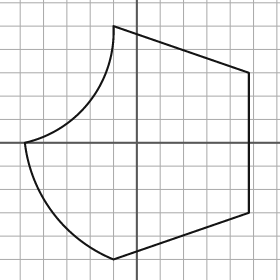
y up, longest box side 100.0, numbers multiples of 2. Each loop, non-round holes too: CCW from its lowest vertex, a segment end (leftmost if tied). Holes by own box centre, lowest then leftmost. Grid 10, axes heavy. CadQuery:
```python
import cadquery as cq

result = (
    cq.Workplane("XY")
    .moveTo(-10.0, -50.0)
    .lineTo(48.0, -30.0)
    .lineTo(48.0, 30.0)
    .lineTo(-10.0, 50.0)
    .threePointArc((-20.0, 18.0), (-48.0, 0.0))
    .threePointArc((-36.0, -30.0), (-10.0, -50.0))
    .close()
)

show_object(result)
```